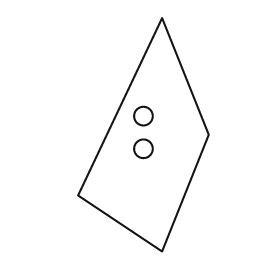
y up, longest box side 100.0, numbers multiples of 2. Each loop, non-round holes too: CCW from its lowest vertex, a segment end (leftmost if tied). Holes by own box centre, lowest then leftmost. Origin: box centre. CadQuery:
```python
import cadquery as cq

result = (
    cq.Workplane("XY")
    .moveTo(8.0, -50.0)
    .lineTo(28.0, 0.0)
    .lineTo(8.0, 50.0)
    .lineTo(-28.0, -26.0)
    .close()
    .moveTo(0.0, -6.0)
    .circle(4.0)
    .moveTo(0.0, 8.0)
    .circle(4.0)
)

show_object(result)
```